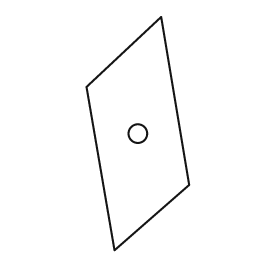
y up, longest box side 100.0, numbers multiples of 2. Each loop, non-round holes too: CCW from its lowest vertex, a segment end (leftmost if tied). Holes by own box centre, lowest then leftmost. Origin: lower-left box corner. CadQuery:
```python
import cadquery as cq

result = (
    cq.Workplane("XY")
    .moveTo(12.0, 0.0)
    .lineTo(44.0, 28.0)
    .lineTo(32.0, 100.0)
    .lineTo(0.0, 70.0)
    .close()
    .moveTo(22.0, 50.0)
    .circle(4.0)
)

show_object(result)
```